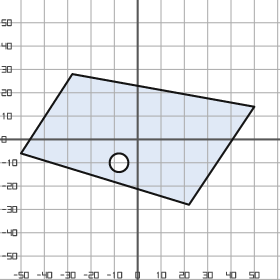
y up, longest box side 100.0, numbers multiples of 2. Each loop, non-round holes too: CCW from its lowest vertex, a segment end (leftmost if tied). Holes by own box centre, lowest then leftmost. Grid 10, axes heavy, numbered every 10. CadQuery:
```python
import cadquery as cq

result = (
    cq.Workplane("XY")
    .moveTo(22.0, -28.0)
    .lineTo(50.0, 14.0)
    .lineTo(-28.0, 28.0)
    .lineTo(-50.0, -6.0)
    .close()
    .moveTo(-8.0, -10.0)
    .circle(4.0)
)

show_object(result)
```